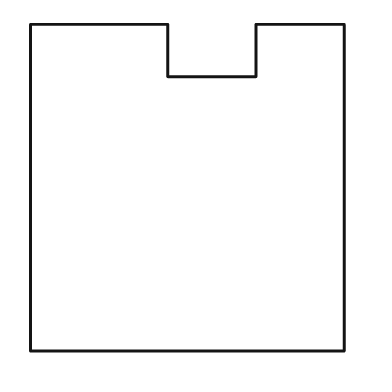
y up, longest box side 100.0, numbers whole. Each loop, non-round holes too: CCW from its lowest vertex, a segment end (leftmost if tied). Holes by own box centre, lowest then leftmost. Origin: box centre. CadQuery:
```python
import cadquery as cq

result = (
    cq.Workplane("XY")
    .moveTo(-48.0, -50.0)
    .lineTo(48.0, -50.0)
    .lineTo(48.0, 50.0)
    .lineTo(21.0, 50.0)
    .lineTo(21.0, 34.0)
    .lineTo(-6.0, 34.0)
    .lineTo(-6.0, 50.0)
    .lineTo(-48.0, 50.0)
    .close()
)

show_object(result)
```